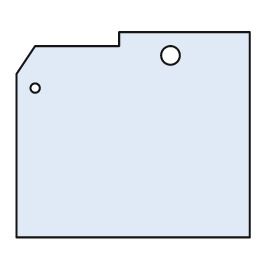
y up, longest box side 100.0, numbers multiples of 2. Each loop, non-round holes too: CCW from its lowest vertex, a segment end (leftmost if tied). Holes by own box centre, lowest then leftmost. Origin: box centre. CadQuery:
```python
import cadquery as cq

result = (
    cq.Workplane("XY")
    .moveTo(-50.0, -44.0)
    .lineTo(50.0, -44.0)
    .lineTo(50.0, 44.0)
    .lineTo(-6.0, 44.0)
    .lineTo(-6.0, 38.0)
    .lineTo(-42.0, 38.0)
    .lineTo(-50.0, 26.0)
    .close()
    .moveTo(-42.0, 20.0)
    .circle(2.0)
    .moveTo(16.0, 34.0)
    .circle(4.0)
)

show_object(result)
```